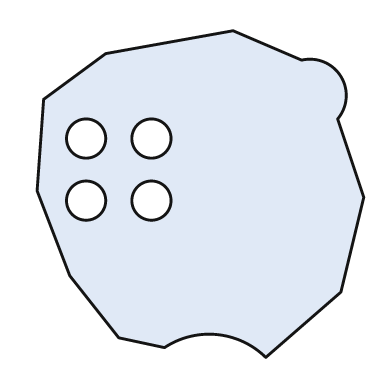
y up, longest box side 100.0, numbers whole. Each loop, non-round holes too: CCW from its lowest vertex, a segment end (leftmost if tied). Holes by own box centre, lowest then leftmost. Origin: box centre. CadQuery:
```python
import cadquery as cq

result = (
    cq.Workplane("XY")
    .moveTo(20.0, -50.0)
    .lineTo(43.0, -30.0)
    .lineTo(50.0, -1.0)
    .lineTo(42.0, 23.0)
    .threePointArc((43.0, 36.0), (31.0, 41.0))
    .lineTo(10.0, 50.0)
    .lineTo(-29.0, 43.0)
    .lineTo(-48.0, 29.0)
    .lineTo(-50.0, 1.0)
    .lineTo(-40.0, -25.0)
    .lineTo(-25.0, -44.0)
    .lineTo(-11.0, -47.0)
    .threePointArc((5.0, -43.0), (20.0, -50.0))
    .close()
    .moveTo(-35.0, -2.0)
    .circle(6.0)
    .moveTo(-15.0, -2.0)
    .circle(6.0)
    .moveTo(-35.0, 17.0)
    .circle(6.0)
    .moveTo(-15.0, 17.0)
    .circle(6.0)
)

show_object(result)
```